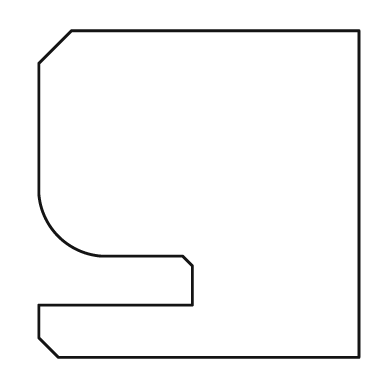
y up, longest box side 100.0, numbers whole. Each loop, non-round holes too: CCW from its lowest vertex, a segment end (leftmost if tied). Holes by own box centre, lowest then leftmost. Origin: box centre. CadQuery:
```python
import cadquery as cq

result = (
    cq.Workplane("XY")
    .moveTo(-43.0, -50.0)
    .lineTo(49.0, -50.0)
    .lineTo(49.0, 50.0)
    .lineTo(-39.0, 50.0)
    .lineTo(-49.0, 40.0)
    .lineTo(-49.0, 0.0)
    .threePointArc((-43.0, -13.0), (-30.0, -19.0))
    .lineTo(-5.0, -19.0)
    .lineTo(-2.0, -22.0)
    .lineTo(-2.0, -34.0)
    .lineTo(-49.0, -34.0)
    .lineTo(-49.0, -44.0)
    .close()
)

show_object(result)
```